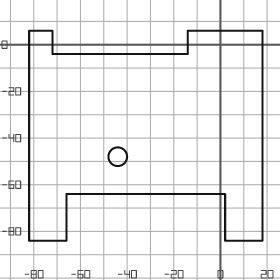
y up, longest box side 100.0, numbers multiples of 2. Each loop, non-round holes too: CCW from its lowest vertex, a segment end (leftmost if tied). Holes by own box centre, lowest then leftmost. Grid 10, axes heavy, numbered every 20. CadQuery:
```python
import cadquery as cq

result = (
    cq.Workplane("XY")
    .moveTo(-82.0, -84.0)
    .lineTo(-66.0, -84.0)
    .lineTo(-66.0, -64.0)
    .lineTo(2.0, -64.0)
    .lineTo(2.0, -84.0)
    .lineTo(18.0, -84.0)
    .lineTo(18.0, 6.0)
    .lineTo(-14.0, 6.0)
    .lineTo(-14.0, -4.0)
    .lineTo(-72.0, -4.0)
    .lineTo(-72.0, 6.0)
    .lineTo(-82.0, 6.0)
    .close()
    .moveTo(-44.0, -48.0)
    .circle(4.0)
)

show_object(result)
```